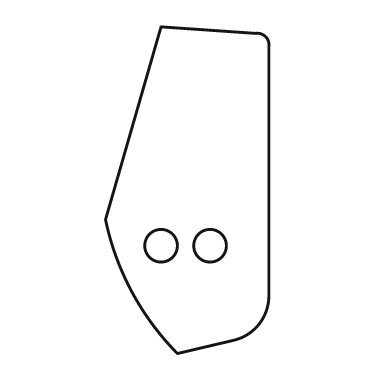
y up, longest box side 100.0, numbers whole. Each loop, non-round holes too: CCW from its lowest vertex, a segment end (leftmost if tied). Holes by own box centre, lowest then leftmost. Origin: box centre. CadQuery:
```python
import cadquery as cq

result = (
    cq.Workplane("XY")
    .moveTo(-3.0, -50.0)
    .lineTo(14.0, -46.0)
    .threePointArc((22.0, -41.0), (25.0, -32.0))
    .lineTo(25.0, 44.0)
    .threePointArc((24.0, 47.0), (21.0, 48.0))
    .lineTo(-8.0, 50.0)
    .lineTo(-25.0, -9.0)
    .threePointArc((-17.0, -31.0), (-3.0, -50.0))
    .close()
    .moveTo(-8.0, -17.0)
    .circle(5.0)
    .moveTo(7.0, -17.0)
    .circle(5.0)
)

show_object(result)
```